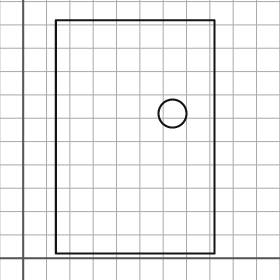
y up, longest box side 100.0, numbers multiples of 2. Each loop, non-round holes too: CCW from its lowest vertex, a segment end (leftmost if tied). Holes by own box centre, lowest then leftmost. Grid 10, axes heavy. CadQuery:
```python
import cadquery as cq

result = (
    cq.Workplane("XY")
    .moveTo(14.0, 2.0)
    .lineTo(82.0, 2.0)
    .lineTo(82.0, 102.0)
    .lineTo(14.0, 102.0)
    .close()
    .moveTo(64.0, 62.0)
    .circle(6.0)
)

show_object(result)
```